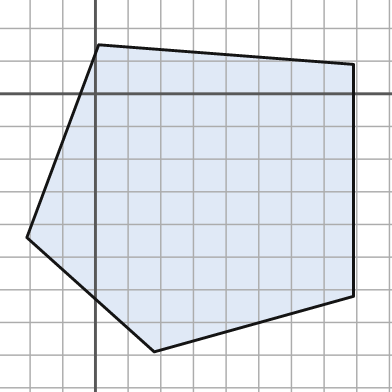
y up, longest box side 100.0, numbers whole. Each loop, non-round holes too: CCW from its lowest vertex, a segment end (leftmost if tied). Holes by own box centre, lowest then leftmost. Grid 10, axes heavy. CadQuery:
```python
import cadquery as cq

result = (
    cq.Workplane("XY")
    .moveTo(18.0, -79.0)
    .lineTo(79.0, -62.0)
    .lineTo(79.0, 9.0)
    .lineTo(1.0, 15.0)
    .lineTo(-21.0, -44.0)
    .close()
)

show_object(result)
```